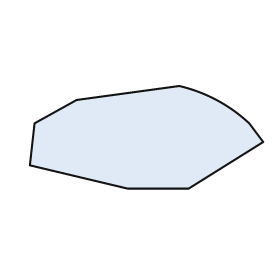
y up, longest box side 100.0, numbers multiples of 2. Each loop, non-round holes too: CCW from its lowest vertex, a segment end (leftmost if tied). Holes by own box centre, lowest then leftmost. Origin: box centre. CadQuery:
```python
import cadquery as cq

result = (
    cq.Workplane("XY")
    .moveTo(-8.0, -22.0)
    .lineTo(18.0, -22.0)
    .lineTo(50.0, -2.0)
    .lineTo(44.0, 6.0)
    .threePointArc((30.0, 16.0), (14.0, 22.0))
    .lineTo(-30.0, 16.0)
    .lineTo(-48.0, 6.0)
    .lineTo(-50.0, -12.0)
    .close()
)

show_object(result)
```